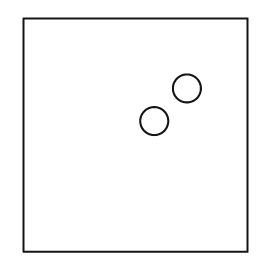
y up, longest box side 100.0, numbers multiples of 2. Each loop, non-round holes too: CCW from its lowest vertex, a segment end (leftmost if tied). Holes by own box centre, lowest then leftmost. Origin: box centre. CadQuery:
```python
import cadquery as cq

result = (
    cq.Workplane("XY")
    .moveTo(-48.0, -50.0)
    .lineTo(48.0, -50.0)
    .lineTo(48.0, 50.0)
    .lineTo(-48.0, 50.0)
    .close()
    .moveTo(8.0, 6.0)
    .circle(6.0)
    .moveTo(22.0, 20.0)
    .circle(6.0)
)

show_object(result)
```